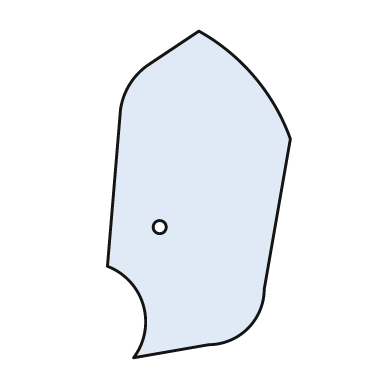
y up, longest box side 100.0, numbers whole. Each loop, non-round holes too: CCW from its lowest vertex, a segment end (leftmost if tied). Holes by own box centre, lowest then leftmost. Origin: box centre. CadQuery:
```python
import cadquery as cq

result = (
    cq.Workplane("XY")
    .moveTo(-20.0, -50.0)
    .lineTo(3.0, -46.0)
    .threePointArc((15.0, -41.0), (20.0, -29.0))
    .lineTo(28.0, 17.0)
    .threePointArc((17.0, 36.0), (0.0, 50.0))
    .lineTo(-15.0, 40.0)
    .threePointArc((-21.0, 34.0), (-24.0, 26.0))
    .lineTo(-28.0, -22.0)
    .threePointArc((-17.0, -34.0), (-20.0, -50.0))
    .close()
    .moveTo(-12.0, -10.0)
    .circle(2.0)
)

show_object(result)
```